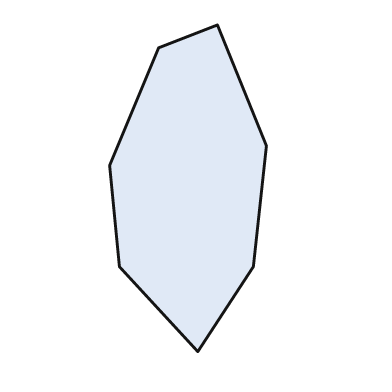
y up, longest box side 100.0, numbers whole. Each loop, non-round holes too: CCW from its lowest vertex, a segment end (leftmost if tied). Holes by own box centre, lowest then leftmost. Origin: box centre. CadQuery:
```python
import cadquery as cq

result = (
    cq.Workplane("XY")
    .moveTo(3.0, -50.0)
    .lineTo(20.0, -24.0)
    .lineTo(24.0, 13.0)
    .lineTo(9.0, 50.0)
    .lineTo(-9.0, 43.0)
    .lineTo(-24.0, 7.0)
    .lineTo(-21.0, -24.0)
    .close()
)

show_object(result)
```